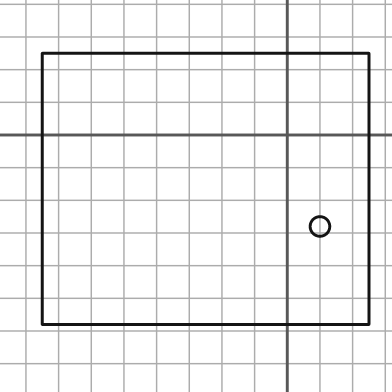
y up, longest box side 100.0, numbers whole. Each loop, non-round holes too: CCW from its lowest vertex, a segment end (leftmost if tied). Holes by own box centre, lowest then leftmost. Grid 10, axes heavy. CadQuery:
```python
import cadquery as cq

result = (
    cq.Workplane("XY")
    .moveTo(-75.0, -58.0)
    .lineTo(25.0, -58.0)
    .lineTo(25.0, 25.0)
    .lineTo(-75.0, 25.0)
    .close()
    .moveTo(10.0, -28.0)
    .circle(3.0)
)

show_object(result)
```